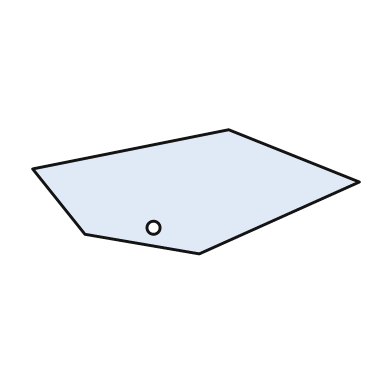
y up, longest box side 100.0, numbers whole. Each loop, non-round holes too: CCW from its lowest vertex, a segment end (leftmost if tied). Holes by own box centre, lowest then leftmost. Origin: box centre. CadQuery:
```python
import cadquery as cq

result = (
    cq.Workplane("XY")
    .moveTo(1.0, -19.0)
    .lineTo(50.0, 3.0)
    .lineTo(10.0, 19.0)
    .lineTo(-50.0, 7.0)
    .lineTo(-34.0, -13.0)
    .close()
    .moveTo(-13.0, -11.0)
    .circle(2.0)
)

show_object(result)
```